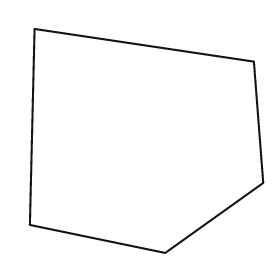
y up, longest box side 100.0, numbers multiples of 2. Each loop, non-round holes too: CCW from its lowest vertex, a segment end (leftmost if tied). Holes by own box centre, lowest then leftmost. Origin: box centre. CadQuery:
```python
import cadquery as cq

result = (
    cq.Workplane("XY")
    .moveTo(8.0, -48.0)
    .lineTo(50.0, -18.0)
    .lineTo(46.0, 34.0)
    .lineTo(-48.0, 48.0)
    .lineTo(-50.0, -36.0)
    .close()
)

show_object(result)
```